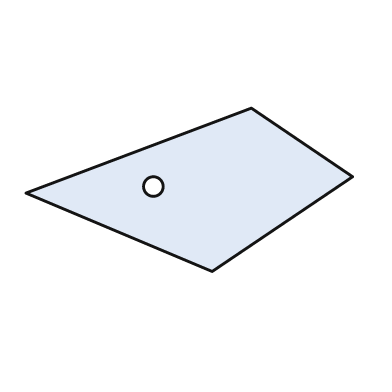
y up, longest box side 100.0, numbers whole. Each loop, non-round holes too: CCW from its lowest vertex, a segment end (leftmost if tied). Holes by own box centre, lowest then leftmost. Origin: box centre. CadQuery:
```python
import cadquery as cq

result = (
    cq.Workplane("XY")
    .moveTo(7.0, -25.0)
    .lineTo(50.0, 4.0)
    .lineTo(19.0, 25.0)
    .lineTo(-50.0, -1.0)
    .close()
    .moveTo(-11.0, 1.0)
    .circle(3.0)
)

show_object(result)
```